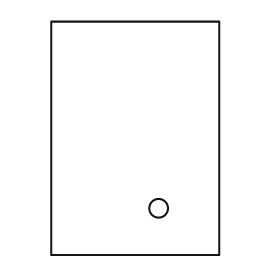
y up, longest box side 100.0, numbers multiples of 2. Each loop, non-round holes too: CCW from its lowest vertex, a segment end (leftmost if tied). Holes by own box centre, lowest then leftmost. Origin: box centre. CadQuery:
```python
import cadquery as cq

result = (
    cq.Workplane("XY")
    .moveTo(-36.0, -50.0)
    .lineTo(36.0, -50.0)
    .lineTo(36.0, 50.0)
    .lineTo(-36.0, 50.0)
    .close()
    .moveTo(10.0, -30.0)
    .circle(4.0)
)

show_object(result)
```